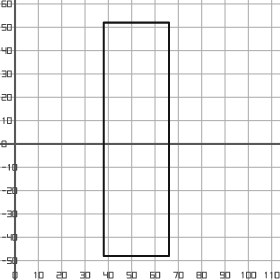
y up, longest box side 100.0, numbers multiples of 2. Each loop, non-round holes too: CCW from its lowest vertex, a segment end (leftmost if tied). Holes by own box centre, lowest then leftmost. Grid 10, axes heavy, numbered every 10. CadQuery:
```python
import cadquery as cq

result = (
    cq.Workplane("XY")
    .moveTo(38.0, -48.0)
    .lineTo(66.0, -48.0)
    .lineTo(66.0, 52.0)
    .lineTo(38.0, 52.0)
    .close()
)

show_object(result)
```